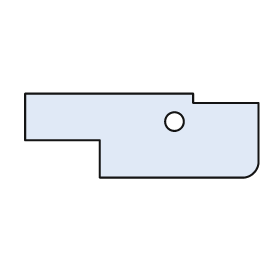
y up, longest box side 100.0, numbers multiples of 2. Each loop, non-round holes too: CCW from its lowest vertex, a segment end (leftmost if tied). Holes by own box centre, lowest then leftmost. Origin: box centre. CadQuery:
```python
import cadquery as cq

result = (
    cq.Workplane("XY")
    .moveTo(-18.0, -18.0)
    .lineTo(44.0, -18.0)
    .threePointArc((48.0, -16.0), (50.0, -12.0))
    .lineTo(50.0, 14.0)
    .lineTo(22.0, 14.0)
    .lineTo(22.0, 18.0)
    .lineTo(-50.0, 18.0)
    .lineTo(-50.0, -2.0)
    .lineTo(-18.0, -2.0)
    .close()
    .moveTo(14.0, 6.0)
    .circle(4.0)
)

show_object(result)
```